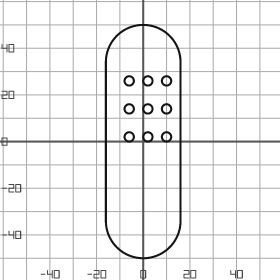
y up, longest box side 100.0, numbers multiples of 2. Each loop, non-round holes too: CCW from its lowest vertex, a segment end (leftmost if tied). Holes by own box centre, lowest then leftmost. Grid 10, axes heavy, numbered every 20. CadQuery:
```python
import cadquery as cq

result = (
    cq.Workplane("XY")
    .moveTo(-16.0, -34.0)
    .threePointArc((0.0, -50.0), (16.0, -34.0))
    .lineTo(16.0, 34.0)
    .threePointArc((0.0, 50.0), (-16.0, 34.0))
    .close()
    .moveTo(-6.0, 2.0)
    .circle(2.0)
    .moveTo(2.0, 2.0)
    .circle(2.0)
    .moveTo(10.0, 2.0)
    .circle(2.0)
    .moveTo(-6.0, 14.0)
    .circle(2.0)
    .moveTo(2.0, 14.0)
    .circle(2.0)
    .moveTo(10.0, 14.0)
    .circle(2.0)
    .moveTo(-6.0, 26.0)
    .circle(2.0)
    .moveTo(2.0, 26.0)
    .circle(2.0)
    .moveTo(10.0, 26.0)
    .circle(2.0)
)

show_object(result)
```